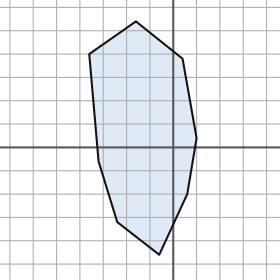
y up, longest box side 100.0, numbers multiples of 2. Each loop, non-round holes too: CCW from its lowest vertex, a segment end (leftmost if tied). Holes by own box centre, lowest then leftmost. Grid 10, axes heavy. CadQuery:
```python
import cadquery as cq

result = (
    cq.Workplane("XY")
    .moveTo(-6.0, -46.0)
    .lineTo(6.0, -20.0)
    .lineTo(10.0, 4.0)
    .lineTo(4.0, 38.0)
    .lineTo(-16.0, 54.0)
    .lineTo(-36.0, 40.0)
    .lineTo(-32.0, -6.0)
    .lineTo(-24.0, -32.0)
    .close()
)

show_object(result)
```